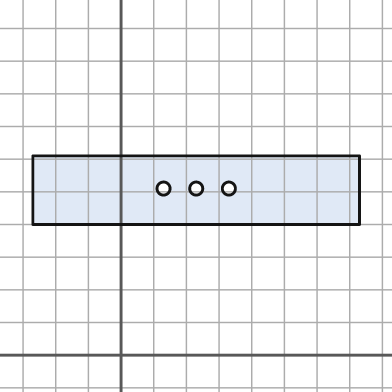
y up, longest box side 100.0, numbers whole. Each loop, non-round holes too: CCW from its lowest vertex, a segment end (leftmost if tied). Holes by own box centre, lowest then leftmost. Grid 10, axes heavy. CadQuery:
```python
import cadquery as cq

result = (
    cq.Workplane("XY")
    .moveTo(-27.0, 40.0)
    .lineTo(73.0, 40.0)
    .lineTo(73.0, 61.0)
    .lineTo(-27.0, 61.0)
    .close()
    .moveTo(13.0, 51.0)
    .circle(2.0)
    .moveTo(23.0, 51.0)
    .circle(2.0)
    .moveTo(33.0, 51.0)
    .circle(2.0)
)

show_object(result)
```